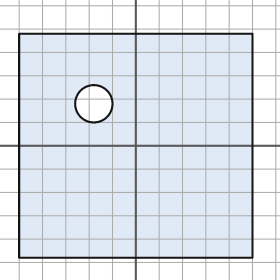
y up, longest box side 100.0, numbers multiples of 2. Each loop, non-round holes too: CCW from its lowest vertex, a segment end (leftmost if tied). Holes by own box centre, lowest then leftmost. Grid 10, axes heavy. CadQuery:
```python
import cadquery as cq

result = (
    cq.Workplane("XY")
    .moveTo(-50.0, -48.0)
    .lineTo(50.0, -48.0)
    .lineTo(50.0, 48.0)
    .lineTo(-50.0, 48.0)
    .close()
    .moveTo(-18.0, 18.0)
    .circle(8.0)
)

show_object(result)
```